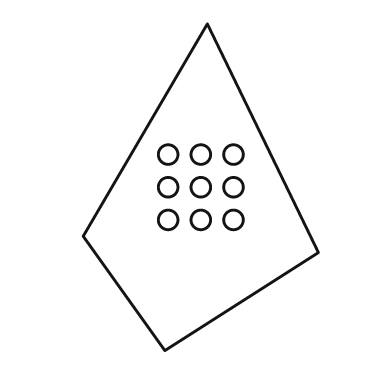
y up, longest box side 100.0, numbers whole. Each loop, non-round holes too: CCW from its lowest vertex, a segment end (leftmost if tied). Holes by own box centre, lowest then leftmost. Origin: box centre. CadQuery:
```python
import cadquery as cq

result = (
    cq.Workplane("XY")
    .moveTo(-11.0, -50.0)
    .lineTo(36.0, -20.0)
    .lineTo(2.0, 50.0)
    .lineTo(-36.0, -15.0)
    .close()
    .moveTo(-10.0, -10.0)
    .circle(3.0)
    .moveTo(0.0, -10.0)
    .circle(3.0)
    .moveTo(10.0, -10.0)
    .circle(3.0)
    .moveTo(-10.0, 0.0)
    .circle(3.0)
    .moveTo(0.0, 0.0)
    .circle(3.0)
    .moveTo(10.0, 0.0)
    .circle(3.0)
    .moveTo(-10.0, 10.0)
    .circle(3.0)
    .moveTo(0.0, 10.0)
    .circle(3.0)
    .moveTo(10.0, 10.0)
    .circle(3.0)
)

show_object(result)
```